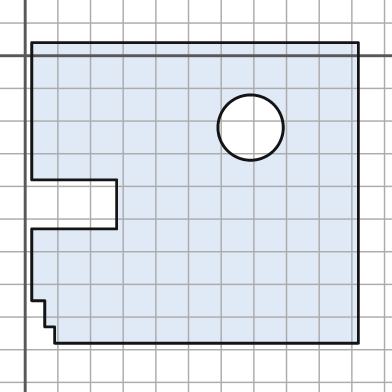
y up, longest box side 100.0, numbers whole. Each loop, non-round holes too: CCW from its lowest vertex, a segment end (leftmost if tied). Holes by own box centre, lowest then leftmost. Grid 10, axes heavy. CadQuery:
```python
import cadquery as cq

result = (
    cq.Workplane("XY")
    .moveTo(9.0, -88.0)
    .lineTo(102.0, -88.0)
    .lineTo(102.0, 4.0)
    .lineTo(2.0, 4.0)
    .lineTo(2.0, -38.0)
    .lineTo(28.0, -38.0)
    .lineTo(28.0, -53.0)
    .lineTo(2.0, -53.0)
    .lineTo(2.0, -75.0)
    .lineTo(6.0, -75.0)
    .lineTo(6.0, -83.0)
    .lineTo(9.0, -83.0)
    .close()
    .moveTo(69.0, -22.0)
    .circle(10.0)
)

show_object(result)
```